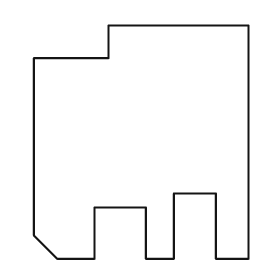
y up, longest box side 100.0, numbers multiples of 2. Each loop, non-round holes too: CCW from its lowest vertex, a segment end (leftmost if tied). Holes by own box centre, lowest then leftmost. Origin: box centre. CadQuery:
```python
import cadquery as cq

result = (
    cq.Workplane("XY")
    .moveTo(-36.0, -50.0)
    .lineTo(-20.0, -50.0)
    .lineTo(-20.0, -28.0)
    .lineTo(2.0, -28.0)
    .lineTo(2.0, -50.0)
    .lineTo(14.0, -50.0)
    .lineTo(14.0, -22.0)
    .lineTo(32.0, -22.0)
    .lineTo(32.0, -50.0)
    .lineTo(46.0, -50.0)
    .lineTo(46.0, 50.0)
    .lineTo(-14.0, 50.0)
    .lineTo(-14.0, 36.0)
    .lineTo(-46.0, 36.0)
    .lineTo(-46.0, -40.0)
    .close()
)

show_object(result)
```